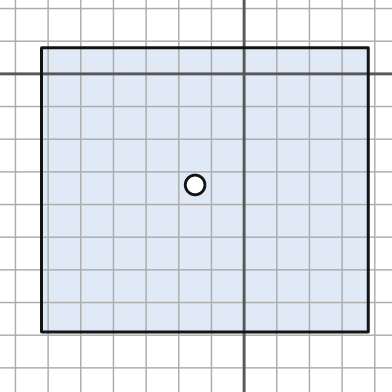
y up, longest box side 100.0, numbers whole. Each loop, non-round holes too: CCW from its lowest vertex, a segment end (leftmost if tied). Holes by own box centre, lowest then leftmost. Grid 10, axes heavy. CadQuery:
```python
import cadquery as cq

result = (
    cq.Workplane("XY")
    .moveTo(-62.0, -79.0)
    .lineTo(38.0, -79.0)
    .lineTo(38.0, 8.0)
    .lineTo(-62.0, 8.0)
    .close()
    .moveTo(-15.0, -34.0)
    .circle(3.0)
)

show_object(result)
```